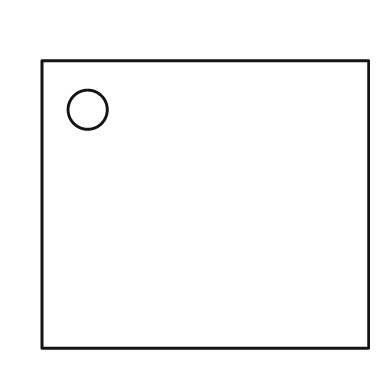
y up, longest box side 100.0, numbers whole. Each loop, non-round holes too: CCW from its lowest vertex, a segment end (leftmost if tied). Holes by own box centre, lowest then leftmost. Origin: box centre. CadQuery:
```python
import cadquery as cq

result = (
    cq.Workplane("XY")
    .moveTo(-50.0, -44.0)
    .lineTo(50.0, -44.0)
    .lineTo(50.0, 44.0)
    .lineTo(-50.0, 44.0)
    .close()
    .moveTo(-36.0, 29.0)
    .circle(6.0)
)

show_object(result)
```